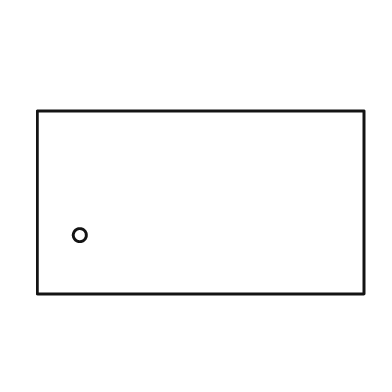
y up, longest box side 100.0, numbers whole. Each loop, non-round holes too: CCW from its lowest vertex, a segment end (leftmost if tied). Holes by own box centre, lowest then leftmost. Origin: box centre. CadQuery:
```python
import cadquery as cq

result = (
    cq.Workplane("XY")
    .moveTo(-50.0, -28.0)
    .lineTo(50.0, -28.0)
    .lineTo(50.0, 28.0)
    .lineTo(-50.0, 28.0)
    .close()
    .moveTo(-37.0, -10.0)
    .circle(2.0)
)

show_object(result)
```